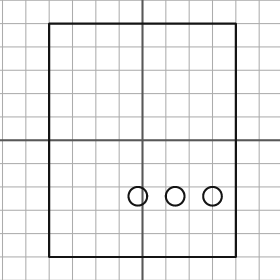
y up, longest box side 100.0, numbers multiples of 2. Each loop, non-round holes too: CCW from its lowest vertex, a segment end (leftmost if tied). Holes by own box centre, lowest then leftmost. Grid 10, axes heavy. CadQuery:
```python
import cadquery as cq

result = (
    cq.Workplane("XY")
    .moveTo(-40.0, -50.0)
    .lineTo(40.0, -50.0)
    .lineTo(40.0, 50.0)
    .lineTo(-40.0, 50.0)
    .close()
    .moveTo(-2.0, -24.0)
    .circle(4.0)
    .moveTo(14.0, -24.0)
    .circle(4.0)
    .moveTo(30.0, -24.0)
    .circle(4.0)
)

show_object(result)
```